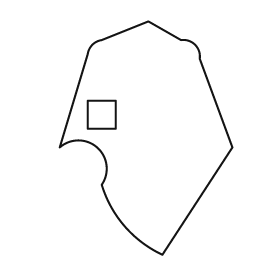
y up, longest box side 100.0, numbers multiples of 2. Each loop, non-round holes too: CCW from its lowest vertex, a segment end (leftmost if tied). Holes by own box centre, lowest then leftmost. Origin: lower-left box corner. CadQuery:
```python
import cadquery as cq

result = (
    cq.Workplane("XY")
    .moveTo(44.0, 0.0)
    .lineTo(74.0, 46.0)
    .lineTo(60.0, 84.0)
    .threePointArc((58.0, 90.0), (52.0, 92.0))
    .lineTo(38.0, 100.0)
    .lineTo(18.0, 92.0)
    .threePointArc((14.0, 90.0), (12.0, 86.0))
    .lineTo(0.0, 46.0)
    .threePointArc((16.0, 46.0), (18.0, 30.0))
    .threePointArc((28.0, 12.0), (44.0, 0.0))
    .close()
    .moveTo(12.0, 54.0)
    .lineTo(24.0, 54.0)
    .lineTo(24.0, 66.0)
    .lineTo(12.0, 66.0)
    .close()
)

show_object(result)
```